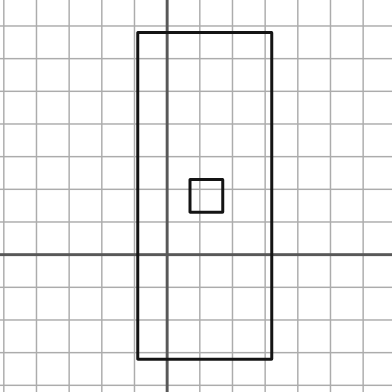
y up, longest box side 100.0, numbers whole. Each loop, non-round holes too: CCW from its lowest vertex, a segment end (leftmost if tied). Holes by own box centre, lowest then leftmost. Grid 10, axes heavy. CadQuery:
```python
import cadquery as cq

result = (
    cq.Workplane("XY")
    .moveTo(-9.0, -32.0)
    .lineTo(32.0, -32.0)
    .lineTo(32.0, 68.0)
    .lineTo(-9.0, 68.0)
    .close()
    .moveTo(7.0, 13.0)
    .lineTo(17.0, 13.0)
    .lineTo(17.0, 23.0)
    .lineTo(7.0, 23.0)
    .close()
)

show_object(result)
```